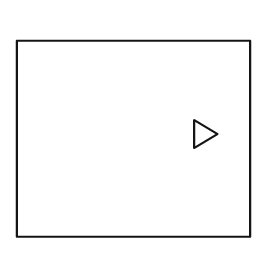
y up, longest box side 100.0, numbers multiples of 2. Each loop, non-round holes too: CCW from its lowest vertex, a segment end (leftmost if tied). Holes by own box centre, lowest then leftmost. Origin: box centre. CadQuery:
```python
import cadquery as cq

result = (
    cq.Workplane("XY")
    .moveTo(-50.0, -42.0)
    .lineTo(50.0, -42.0)
    .lineTo(50.0, 42.0)
    .lineTo(-50.0, 42.0)
    .close()
    .moveTo(26.0, -4.0)
    .lineTo(36.0, 2.0)
    .lineTo(26.0, 8.0)
    .close()
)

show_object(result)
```